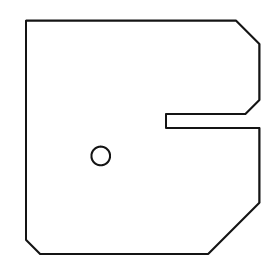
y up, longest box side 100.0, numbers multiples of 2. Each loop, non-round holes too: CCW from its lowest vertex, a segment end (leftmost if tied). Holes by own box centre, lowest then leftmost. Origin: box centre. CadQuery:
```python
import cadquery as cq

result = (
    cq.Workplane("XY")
    .moveTo(-44.0, -50.0)
    .lineTo(28.0, -50.0)
    .lineTo(50.0, -28.0)
    .lineTo(50.0, 4.0)
    .lineTo(10.0, 4.0)
    .lineTo(10.0, 10.0)
    .lineTo(44.0, 10.0)
    .lineTo(50.0, 16.0)
    .lineTo(50.0, 40.0)
    .lineTo(40.0, 50.0)
    .lineTo(-50.0, 50.0)
    .lineTo(-50.0, -44.0)
    .close()
    .moveTo(-18.0, -8.0)
    .circle(4.0)
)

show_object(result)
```